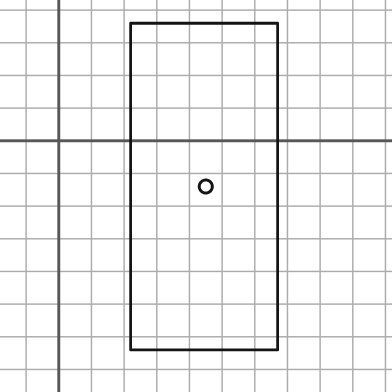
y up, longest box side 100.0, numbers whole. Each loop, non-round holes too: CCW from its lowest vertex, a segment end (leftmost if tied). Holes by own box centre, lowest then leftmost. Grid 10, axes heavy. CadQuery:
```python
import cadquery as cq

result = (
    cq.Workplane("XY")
    .moveTo(22.0, -64.0)
    .lineTo(67.0, -64.0)
    .lineTo(67.0, 36.0)
    .lineTo(22.0, 36.0)
    .close()
    .moveTo(45.0, -14.0)
    .circle(2.0)
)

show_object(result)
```